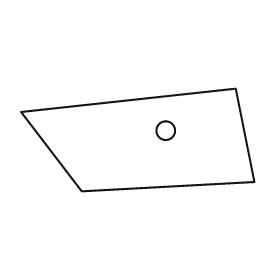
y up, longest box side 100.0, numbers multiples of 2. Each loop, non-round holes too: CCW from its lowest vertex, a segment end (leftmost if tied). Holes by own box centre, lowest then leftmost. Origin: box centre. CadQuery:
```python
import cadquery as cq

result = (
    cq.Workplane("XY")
    .moveTo(-24.0, -22.0)
    .lineTo(50.0, -18.0)
    .lineTo(42.0, 22.0)
    .lineTo(-50.0, 12.0)
    .close()
    .moveTo(12.0, 4.0)
    .circle(4.0)
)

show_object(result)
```